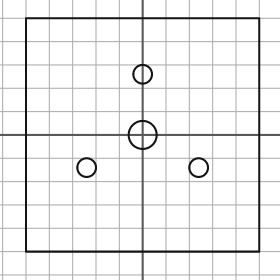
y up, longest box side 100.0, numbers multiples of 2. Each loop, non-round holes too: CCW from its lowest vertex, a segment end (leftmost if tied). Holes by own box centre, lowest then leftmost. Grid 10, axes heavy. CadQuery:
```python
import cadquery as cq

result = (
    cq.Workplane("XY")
    .moveTo(-50.0, -50.0)
    .lineTo(50.0, -50.0)
    .lineTo(50.0, 50.0)
    .lineTo(-50.0, 50.0)
    .close()
    .moveTo(-24.0, -14.0)
    .circle(4.0)
    .moveTo(24.0, -14.0)
    .circle(4.0)
    .moveTo(0.0, 0.0)
    .circle(6.0)
    .moveTo(0.0, 26.0)
    .circle(4.0)
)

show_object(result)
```